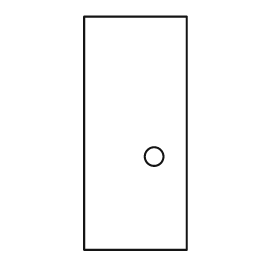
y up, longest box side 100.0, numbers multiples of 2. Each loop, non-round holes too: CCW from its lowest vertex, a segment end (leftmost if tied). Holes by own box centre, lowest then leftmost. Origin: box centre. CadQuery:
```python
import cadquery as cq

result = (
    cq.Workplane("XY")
    .moveTo(-22.0, -50.0)
    .lineTo(22.0, -50.0)
    .lineTo(22.0, 50.0)
    .lineTo(-22.0, 50.0)
    .close()
    .moveTo(8.0, -10.0)
    .circle(4.0)
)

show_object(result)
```